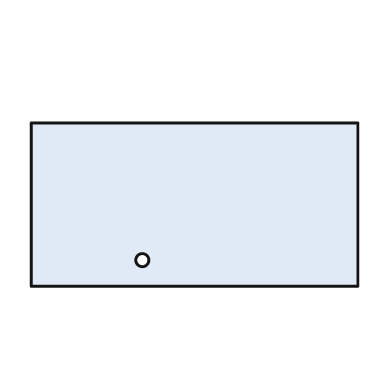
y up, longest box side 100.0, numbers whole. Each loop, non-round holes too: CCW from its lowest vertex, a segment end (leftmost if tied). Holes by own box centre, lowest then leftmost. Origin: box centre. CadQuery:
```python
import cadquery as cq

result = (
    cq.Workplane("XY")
    .moveTo(-50.0, -25.0)
    .lineTo(50.0, -25.0)
    .lineTo(50.0, 25.0)
    .lineTo(-50.0, 25.0)
    .close()
    .moveTo(-16.0, -17.0)
    .circle(2.0)
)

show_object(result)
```